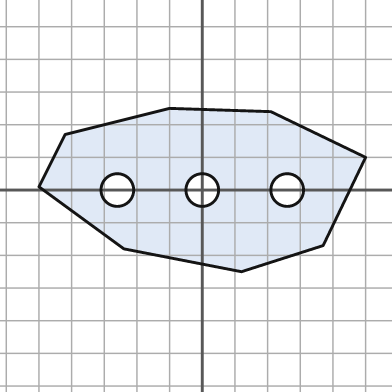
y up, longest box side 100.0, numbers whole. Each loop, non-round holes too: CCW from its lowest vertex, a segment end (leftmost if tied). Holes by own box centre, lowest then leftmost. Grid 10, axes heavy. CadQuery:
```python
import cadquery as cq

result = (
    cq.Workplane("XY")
    .moveTo(12.0, -25.0)
    .lineTo(37.0, -17.0)
    .lineTo(50.0, 10.0)
    .lineTo(21.0, 24.0)
    .lineTo(-10.0, 25.0)
    .lineTo(-42.0, 17.0)
    .lineTo(-50.0, 1.0)
    .lineTo(-24.0, -18.0)
    .close()
    .moveTo(-26.0, 0.0)
    .circle(5.0)
    .moveTo(0.0, 0.0)
    .circle(5.0)
    .moveTo(26.0, 0.0)
    .circle(5.0)
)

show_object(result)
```